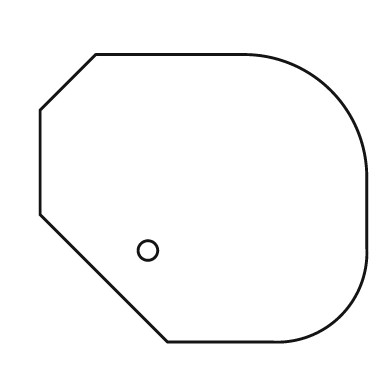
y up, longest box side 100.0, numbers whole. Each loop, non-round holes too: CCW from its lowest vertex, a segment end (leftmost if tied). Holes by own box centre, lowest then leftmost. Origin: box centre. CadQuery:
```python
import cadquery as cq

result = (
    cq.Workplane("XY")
    .moveTo(-11.0, -44.0)
    .lineTo(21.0, -44.0)
    .threePointArc((42.0, -36.0), (50.0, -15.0))
    .lineTo(50.0, 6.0)
    .threePointArc((39.0, 33.0), (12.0, 44.0))
    .lineTo(-33.0, 44.0)
    .lineTo(-50.0, 27.0)
    .lineTo(-50.0, -5.0)
    .close()
    .moveTo(-17.0, -16.0)
    .circle(3.0)
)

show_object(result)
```